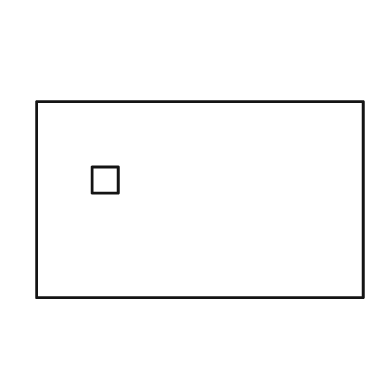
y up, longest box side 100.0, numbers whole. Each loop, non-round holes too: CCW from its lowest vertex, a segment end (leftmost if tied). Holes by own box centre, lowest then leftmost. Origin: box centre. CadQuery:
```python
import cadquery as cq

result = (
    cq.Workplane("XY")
    .moveTo(-50.0, -30.0)
    .lineTo(50.0, -30.0)
    .lineTo(50.0, 30.0)
    .lineTo(-50.0, 30.0)
    .close()
    .moveTo(-33.0, 2.0)
    .lineTo(-25.0, 2.0)
    .lineTo(-25.0, 10.0)
    .lineTo(-33.0, 10.0)
    .close()
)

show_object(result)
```